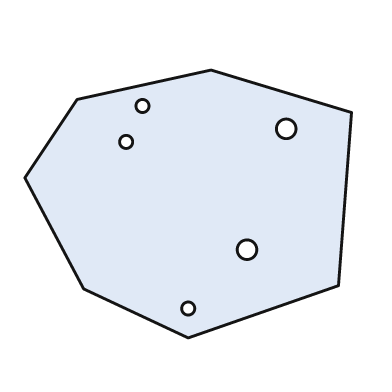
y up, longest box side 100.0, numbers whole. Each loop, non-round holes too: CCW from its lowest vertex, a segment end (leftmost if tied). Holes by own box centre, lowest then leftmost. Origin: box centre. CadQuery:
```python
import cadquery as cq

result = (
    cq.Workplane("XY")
    .moveTo(0.0, -41.0)
    .lineTo(46.0, -25.0)
    .lineTo(50.0, 28.0)
    .lineTo(7.0, 41.0)
    .lineTo(-34.0, 32.0)
    .lineTo(-50.0, 8.0)
    .lineTo(-32.0, -26.0)
    .close()
    .moveTo(0.0, -32.0)
    .circle(2.0)
    .moveTo(18.0, -14.0)
    .circle(3.0)
    .moveTo(-19.0, 19.0)
    .circle(2.0)
    .moveTo(30.0, 23.0)
    .circle(3.0)
    .moveTo(-14.0, 30.0)
    .circle(2.0)
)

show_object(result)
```